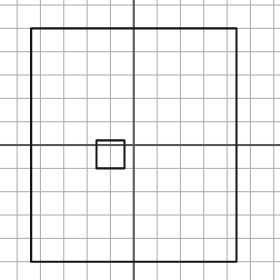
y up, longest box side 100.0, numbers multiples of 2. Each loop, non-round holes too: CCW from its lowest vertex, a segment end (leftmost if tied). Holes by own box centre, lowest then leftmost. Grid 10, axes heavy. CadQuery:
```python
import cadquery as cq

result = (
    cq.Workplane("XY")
    .moveTo(-44.0, -50.0)
    .lineTo(44.0, -50.0)
    .lineTo(44.0, 50.0)
    .lineTo(-44.0, 50.0)
    .close()
    .moveTo(-16.0, -10.0)
    .lineTo(-4.0, -10.0)
    .lineTo(-4.0, 2.0)
    .lineTo(-16.0, 2.0)
    .close()
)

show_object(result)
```